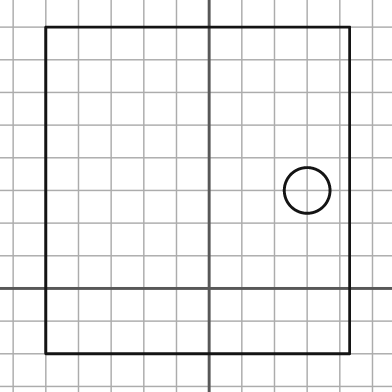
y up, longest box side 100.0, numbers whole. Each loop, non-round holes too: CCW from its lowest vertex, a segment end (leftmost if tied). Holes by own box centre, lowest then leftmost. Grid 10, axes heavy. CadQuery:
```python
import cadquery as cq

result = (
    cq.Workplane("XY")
    .moveTo(-50.0, -20.0)
    .lineTo(43.0, -20.0)
    .lineTo(43.0, 80.0)
    .lineTo(-50.0, 80.0)
    .close()
    .moveTo(30.0, 30.0)
    .circle(7.0)
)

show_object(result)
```